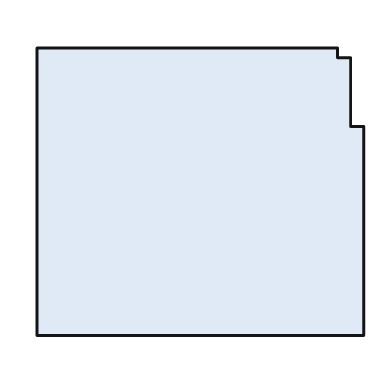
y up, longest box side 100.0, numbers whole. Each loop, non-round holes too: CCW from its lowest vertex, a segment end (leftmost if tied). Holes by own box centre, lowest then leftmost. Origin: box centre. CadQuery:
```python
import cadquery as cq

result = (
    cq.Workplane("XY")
    .moveTo(-50.0, -44.0)
    .lineTo(50.0, -44.0)
    .lineTo(50.0, 20.0)
    .lineTo(46.0, 20.0)
    .lineTo(46.0, 41.0)
    .lineTo(42.0, 41.0)
    .lineTo(42.0, 44.0)
    .lineTo(-50.0, 44.0)
    .close()
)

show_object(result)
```